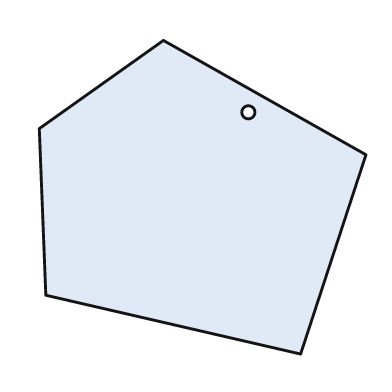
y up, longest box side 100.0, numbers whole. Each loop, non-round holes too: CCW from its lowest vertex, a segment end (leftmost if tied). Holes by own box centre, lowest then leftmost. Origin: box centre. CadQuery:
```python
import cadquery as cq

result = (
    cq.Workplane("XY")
    .moveTo(30.0, -48.0)
    .lineTo(50.0, 13.0)
    .lineTo(-12.0, 48.0)
    .lineTo(-50.0, 21.0)
    .lineTo(-48.0, -30.0)
    .close()
    .moveTo(14.0, 26.0)
    .circle(2.0)
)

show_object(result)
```